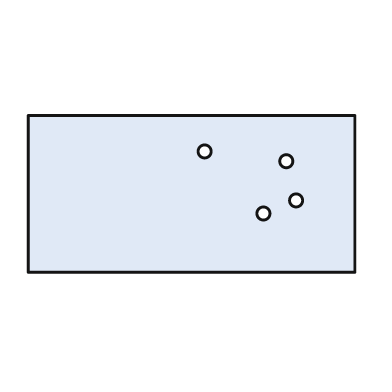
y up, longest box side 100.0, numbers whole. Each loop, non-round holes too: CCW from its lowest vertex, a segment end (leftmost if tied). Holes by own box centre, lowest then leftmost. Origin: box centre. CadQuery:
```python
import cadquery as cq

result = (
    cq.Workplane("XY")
    .moveTo(-50.0, -24.0)
    .lineTo(50.0, -24.0)
    .lineTo(50.0, 24.0)
    .lineTo(-50.0, 24.0)
    .close()
    .moveTo(22.0, -6.0)
    .circle(2.0)
    .moveTo(32.0, -2.0)
    .circle(2.0)
    .moveTo(29.0, 10.0)
    .circle(2.0)
    .moveTo(4.0, 13.0)
    .circle(2.0)
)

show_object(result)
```